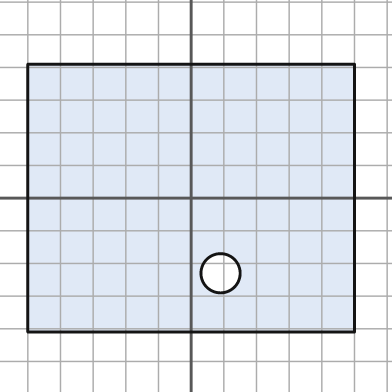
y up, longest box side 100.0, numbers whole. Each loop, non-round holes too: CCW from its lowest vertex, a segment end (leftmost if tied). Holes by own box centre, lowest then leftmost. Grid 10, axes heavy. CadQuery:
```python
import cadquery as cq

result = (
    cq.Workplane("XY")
    .moveTo(-50.0, -41.0)
    .lineTo(50.0, -41.0)
    .lineTo(50.0, 41.0)
    .lineTo(-50.0, 41.0)
    .close()
    .moveTo(9.0, -23.0)
    .circle(6.0)
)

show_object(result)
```